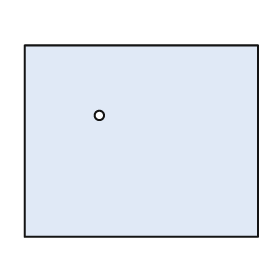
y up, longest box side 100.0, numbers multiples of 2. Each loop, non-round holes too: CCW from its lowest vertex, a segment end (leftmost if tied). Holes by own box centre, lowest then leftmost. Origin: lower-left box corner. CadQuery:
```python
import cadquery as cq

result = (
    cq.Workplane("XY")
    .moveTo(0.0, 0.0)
    .lineTo(100.0, 0.0)
    .lineTo(100.0, 82.0)
    .lineTo(0.0, 82.0)
    .close()
    .moveTo(32.0, 52.0)
    .circle(2.0)
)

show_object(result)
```